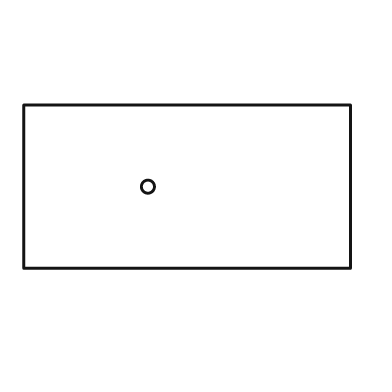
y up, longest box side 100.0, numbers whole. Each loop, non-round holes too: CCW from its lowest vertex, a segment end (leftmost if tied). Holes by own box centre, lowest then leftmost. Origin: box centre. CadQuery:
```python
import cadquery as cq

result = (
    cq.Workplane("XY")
    .moveTo(-50.0, -25.0)
    .lineTo(50.0, -25.0)
    .lineTo(50.0, 25.0)
    .lineTo(-50.0, 25.0)
    .close()
    .moveTo(-12.0, 0.0)
    .circle(2.0)
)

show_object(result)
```